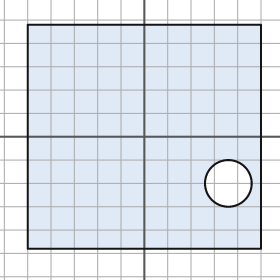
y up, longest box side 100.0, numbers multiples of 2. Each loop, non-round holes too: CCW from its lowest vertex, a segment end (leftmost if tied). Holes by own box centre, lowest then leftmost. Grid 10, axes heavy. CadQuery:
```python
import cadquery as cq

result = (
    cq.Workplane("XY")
    .moveTo(-50.0, -48.0)
    .lineTo(50.0, -48.0)
    .lineTo(50.0, 48.0)
    .lineTo(-50.0, 48.0)
    .close()
    .moveTo(36.0, -20.0)
    .circle(10.0)
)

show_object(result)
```